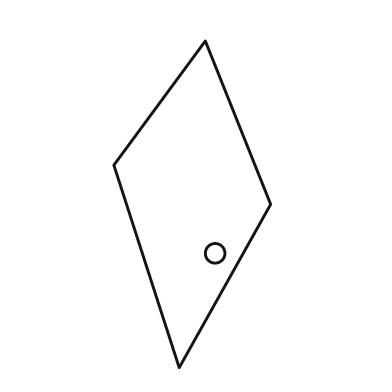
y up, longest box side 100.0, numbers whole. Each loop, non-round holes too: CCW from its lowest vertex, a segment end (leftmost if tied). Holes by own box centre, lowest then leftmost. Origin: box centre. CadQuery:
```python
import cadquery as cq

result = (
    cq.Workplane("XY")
    .moveTo(-4.0, -50.0)
    .lineTo(24.0, 0.0)
    .lineTo(4.0, 50.0)
    .lineTo(-24.0, 12.0)
    .close()
    .moveTo(7.0, -15.0)
    .circle(3.0)
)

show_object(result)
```